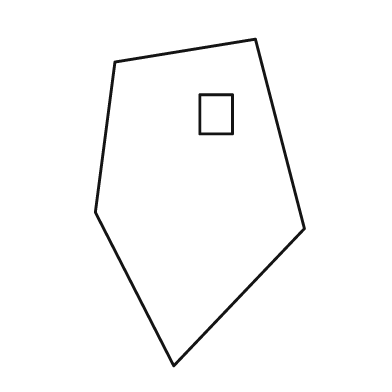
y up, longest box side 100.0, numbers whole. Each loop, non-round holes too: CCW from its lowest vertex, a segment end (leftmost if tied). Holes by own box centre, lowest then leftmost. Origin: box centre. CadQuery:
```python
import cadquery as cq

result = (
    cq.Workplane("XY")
    .moveTo(-8.0, -50.0)
    .lineTo(32.0, -8.0)
    .lineTo(17.0, 50.0)
    .lineTo(-26.0, 43.0)
    .lineTo(-32.0, -3.0)
    .close()
    .moveTo(0.0, 21.0)
    .lineTo(10.0, 21.0)
    .lineTo(10.0, 33.0)
    .lineTo(0.0, 33.0)
    .close()
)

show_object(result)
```